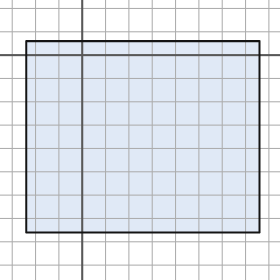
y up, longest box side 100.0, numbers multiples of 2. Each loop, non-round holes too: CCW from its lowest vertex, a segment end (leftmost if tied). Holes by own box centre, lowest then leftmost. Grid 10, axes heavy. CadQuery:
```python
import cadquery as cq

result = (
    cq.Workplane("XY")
    .moveTo(-24.0, -76.0)
    .lineTo(76.0, -76.0)
    .lineTo(76.0, 6.0)
    .lineTo(-24.0, 6.0)
    .close()
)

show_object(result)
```